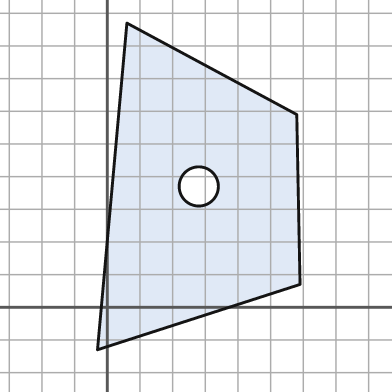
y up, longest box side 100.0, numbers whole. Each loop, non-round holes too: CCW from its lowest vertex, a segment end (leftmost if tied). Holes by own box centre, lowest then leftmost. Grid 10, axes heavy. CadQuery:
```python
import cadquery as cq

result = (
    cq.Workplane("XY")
    .moveTo(-3.0, -13.0)
    .lineTo(59.0, 7.0)
    .lineTo(58.0, 59.0)
    .lineTo(6.0, 87.0)
    .close()
    .moveTo(28.0, 37.0)
    .circle(6.0)
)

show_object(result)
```